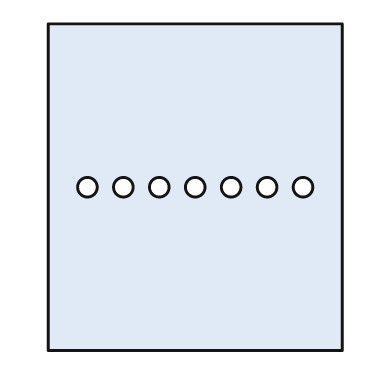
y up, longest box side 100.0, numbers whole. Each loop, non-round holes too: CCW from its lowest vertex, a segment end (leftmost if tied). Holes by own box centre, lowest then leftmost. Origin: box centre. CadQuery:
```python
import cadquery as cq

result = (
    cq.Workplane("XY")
    .moveTo(-45.0, -50.0)
    .lineTo(45.0, -50.0)
    .lineTo(45.0, 50.0)
    .lineTo(-45.0, 50.0)
    .close()
    .moveTo(-33.0, 0.0)
    .circle(3.0)
    .moveTo(-22.0, 0.0)
    .circle(3.0)
    .moveTo(-11.0, 0.0)
    .circle(3.0)
    .moveTo(0.0, 0.0)
    .circle(3.0)
    .moveTo(11.0, 0.0)
    .circle(3.0)
    .moveTo(22.0, 0.0)
    .circle(3.0)
    .moveTo(33.0, 0.0)
    .circle(3.0)
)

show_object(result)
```